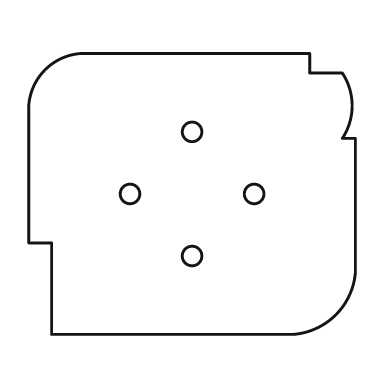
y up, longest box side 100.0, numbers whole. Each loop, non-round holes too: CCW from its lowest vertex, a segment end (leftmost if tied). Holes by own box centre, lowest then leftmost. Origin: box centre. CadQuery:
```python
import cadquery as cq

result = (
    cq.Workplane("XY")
    .moveTo(-43.0, -43.0)
    .lineTo(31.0, -43.0)
    .threePointArc((44.0, -37.0), (50.0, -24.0))
    .lineTo(50.0, 17.0)
    .lineTo(46.0, 17.0)
    .threePointArc((49.0, 27.0), (46.0, 37.0))
    .lineTo(36.0, 37.0)
    .lineTo(36.0, 43.0)
    .lineTo(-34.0, 43.0)
    .threePointArc((-45.0, 38.0), (-50.0, 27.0))
    .lineTo(-50.0, -15.0)
    .lineTo(-43.0, -15.0)
    .close()
    .moveTo(0.0, -19.0)
    .circle(3.0)
    .moveTo(-19.0, 0.0)
    .circle(3.0)
    .moveTo(19.0, 0.0)
    .circle(3.0)
    .moveTo(0.0, 19.0)
    .circle(3.0)
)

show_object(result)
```